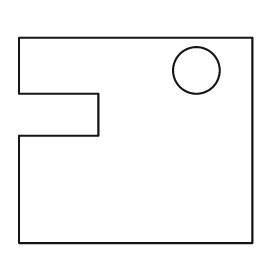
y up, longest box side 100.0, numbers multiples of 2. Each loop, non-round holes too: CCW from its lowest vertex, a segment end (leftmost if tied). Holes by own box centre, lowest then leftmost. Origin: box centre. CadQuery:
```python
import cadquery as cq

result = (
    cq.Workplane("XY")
    .moveTo(-50.0, -44.0)
    .lineTo(50.0, -44.0)
    .lineTo(50.0, 44.0)
    .lineTo(-50.0, 44.0)
    .lineTo(-50.0, 20.0)
    .lineTo(-16.0, 20.0)
    .lineTo(-16.0, 2.0)
    .lineTo(-50.0, 2.0)
    .close()
    .moveTo(26.0, 30.0)
    .circle(10.0)
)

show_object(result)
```